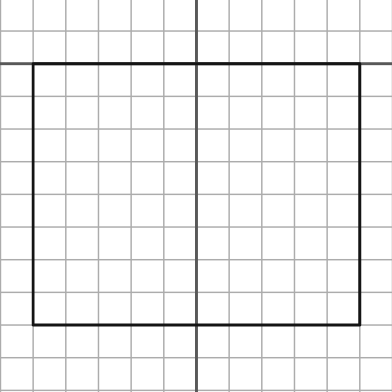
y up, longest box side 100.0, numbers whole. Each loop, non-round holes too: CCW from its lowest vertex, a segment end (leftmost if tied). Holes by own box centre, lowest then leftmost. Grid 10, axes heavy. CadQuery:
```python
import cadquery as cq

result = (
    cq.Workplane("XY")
    .moveTo(-50.0, -80.0)
    .lineTo(50.0, -80.0)
    .lineTo(50.0, 0.0)
    .lineTo(-50.0, 0.0)
    .close()
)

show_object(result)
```